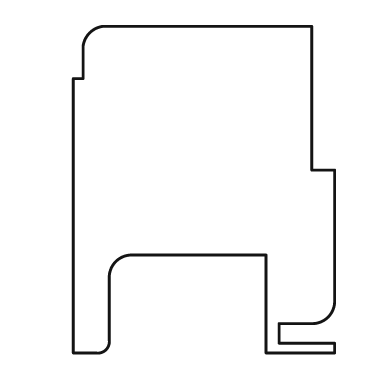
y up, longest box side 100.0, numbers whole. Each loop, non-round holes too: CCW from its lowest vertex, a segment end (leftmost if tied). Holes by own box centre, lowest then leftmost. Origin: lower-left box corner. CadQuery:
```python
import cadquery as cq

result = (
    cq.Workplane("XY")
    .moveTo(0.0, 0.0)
    .lineTo(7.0, 0.0)
    .threePointArc((10.0, 1.0), (11.0, 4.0))
    .lineTo(11.0, 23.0)
    .threePointArc((13.0, 28.0), (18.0, 30.0))
    .lineTo(59.0, 30.0)
    .lineTo(59.0, 0.0)
    .lineTo(80.0, 0.0)
    .lineTo(80.0, 3.0)
    .lineTo(63.0, 3.0)
    .lineTo(63.0, 9.0)
    .lineTo(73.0, 9.0)
    .threePointArc((78.0, 11.0), (80.0, 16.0))
    .lineTo(80.0, 56.0)
    .lineTo(73.0, 56.0)
    .lineTo(73.0, 100.0)
    .lineTo(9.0, 100.0)
    .threePointArc((5.0, 98.0), (3.0, 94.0))
    .lineTo(3.0, 84.0)
    .lineTo(0.0, 84.0)
    .close()
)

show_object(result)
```